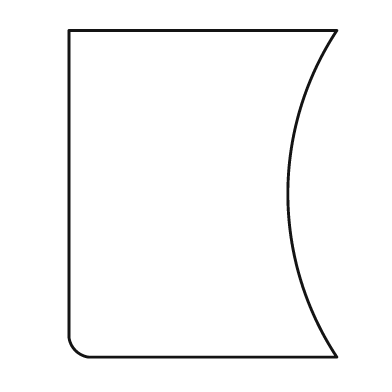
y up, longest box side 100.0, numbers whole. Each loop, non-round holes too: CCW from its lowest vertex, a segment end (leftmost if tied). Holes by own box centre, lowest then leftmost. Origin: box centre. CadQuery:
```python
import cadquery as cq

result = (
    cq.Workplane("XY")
    .moveTo(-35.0, -50.0)
    .lineTo(41.0, -50.0)
    .threePointArc((26.0, 0.0), (41.0, 50.0))
    .lineTo(-41.0, 50.0)
    .lineTo(-41.0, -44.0)
    .threePointArc((-39.0, -48.0), (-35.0, -50.0))
    .close()
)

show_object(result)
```